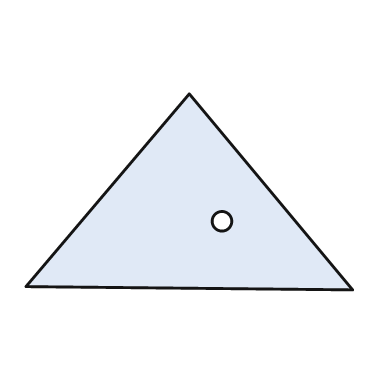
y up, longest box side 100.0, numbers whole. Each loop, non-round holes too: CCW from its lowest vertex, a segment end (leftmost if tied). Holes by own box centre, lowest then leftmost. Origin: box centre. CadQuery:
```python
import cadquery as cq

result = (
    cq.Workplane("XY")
    .moveTo(50.0, -30.0)
    .lineTo(0.0, 30.0)
    .lineTo(-50.0, -29.0)
    .close()
    .moveTo(10.0, -9.0)
    .circle(3.0)
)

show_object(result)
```